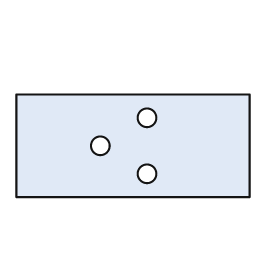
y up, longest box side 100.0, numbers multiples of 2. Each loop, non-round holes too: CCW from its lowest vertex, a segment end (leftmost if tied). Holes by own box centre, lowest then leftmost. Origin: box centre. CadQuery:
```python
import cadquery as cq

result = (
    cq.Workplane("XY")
    .moveTo(-50.0, -22.0)
    .lineTo(50.0, -22.0)
    .lineTo(50.0, 22.0)
    .lineTo(-50.0, 22.0)
    .close()
    .moveTo(6.0, -12.0)
    .circle(4.0)
    .moveTo(-14.0, 0.0)
    .circle(4.0)
    .moveTo(6.0, 12.0)
    .circle(4.0)
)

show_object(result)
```